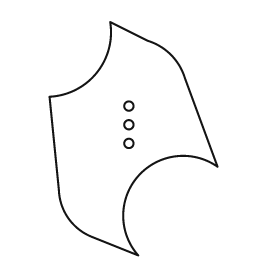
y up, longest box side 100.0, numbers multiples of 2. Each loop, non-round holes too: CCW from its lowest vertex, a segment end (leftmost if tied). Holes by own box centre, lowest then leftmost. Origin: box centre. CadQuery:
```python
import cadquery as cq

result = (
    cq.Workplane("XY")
    .moveTo(2.0, -50.0)
    .threePointArc((2.0, -16.0), (36.0, -12.0))
    .lineTo(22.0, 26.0)
    .threePointArc((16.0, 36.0), (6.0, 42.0))
    .lineTo(-10.0, 50.0)
    .threePointArc((-16.0, 28.0), (-36.0, 18.0))
    .lineTo(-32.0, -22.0)
    .threePointArc((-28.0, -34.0), (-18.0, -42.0))
    .close()
    .moveTo(-2.0, -2.0)
    .circle(2.0)
    .moveTo(-2.0, 6.0)
    .circle(2.0)
    .moveTo(-2.0, 14.0)
    .circle(2.0)
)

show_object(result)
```